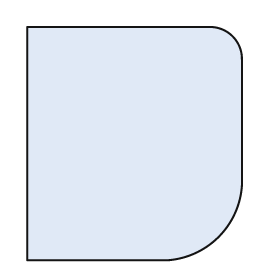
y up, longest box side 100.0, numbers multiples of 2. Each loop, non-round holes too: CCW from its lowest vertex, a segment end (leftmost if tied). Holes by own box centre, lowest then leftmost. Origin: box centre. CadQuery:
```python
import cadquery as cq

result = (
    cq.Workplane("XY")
    .moveTo(-46.0, -50.0)
    .lineTo(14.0, -50.0)
    .threePointArc((36.0, -40.0), (46.0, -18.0))
    .lineTo(46.0, 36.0)
    .threePointArc((42.0, 46.0), (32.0, 50.0))
    .lineTo(-46.0, 50.0)
    .close()
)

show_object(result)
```